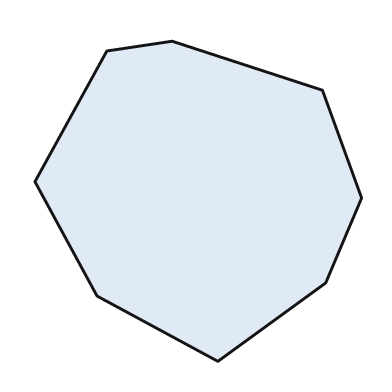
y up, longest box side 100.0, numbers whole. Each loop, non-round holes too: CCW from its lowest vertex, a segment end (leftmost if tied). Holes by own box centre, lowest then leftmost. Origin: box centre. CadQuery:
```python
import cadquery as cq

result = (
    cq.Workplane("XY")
    .moveTo(6.0, -49.0)
    .lineTo(39.0, -25.0)
    .lineTo(50.0, 1.0)
    .lineTo(38.0, 34.0)
    .lineTo(-8.0, 49.0)
    .lineTo(-28.0, 46.0)
    .lineTo(-50.0, 6.0)
    .lineTo(-31.0, -29.0)
    .close()
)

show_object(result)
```